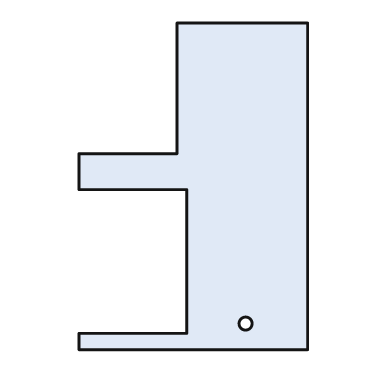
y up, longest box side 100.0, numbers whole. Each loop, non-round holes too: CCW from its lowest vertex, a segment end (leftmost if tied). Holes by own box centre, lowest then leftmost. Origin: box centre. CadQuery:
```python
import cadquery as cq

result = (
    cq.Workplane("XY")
    .moveTo(-35.0, -50.0)
    .lineTo(35.0, -50.0)
    .lineTo(35.0, 50.0)
    .lineTo(-5.0, 50.0)
    .lineTo(-5.0, 10.0)
    .lineTo(-35.0, 10.0)
    .lineTo(-35.0, -1.0)
    .lineTo(-2.0, -1.0)
    .lineTo(-2.0, -45.0)
    .lineTo(-35.0, -45.0)
    .close()
    .moveTo(16.0, -42.0)
    .circle(2.0)
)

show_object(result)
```